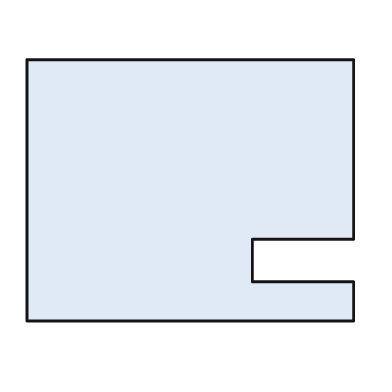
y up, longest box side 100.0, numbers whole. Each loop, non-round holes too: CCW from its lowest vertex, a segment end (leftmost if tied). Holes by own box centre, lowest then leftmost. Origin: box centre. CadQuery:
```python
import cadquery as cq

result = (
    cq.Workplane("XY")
    .moveTo(-50.0, -40.0)
    .lineTo(50.0, -40.0)
    .lineTo(50.0, -28.0)
    .lineTo(19.0, -28.0)
    .lineTo(19.0, -15.0)
    .lineTo(50.0, -15.0)
    .lineTo(50.0, 40.0)
    .lineTo(-50.0, 40.0)
    .close()
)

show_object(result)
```